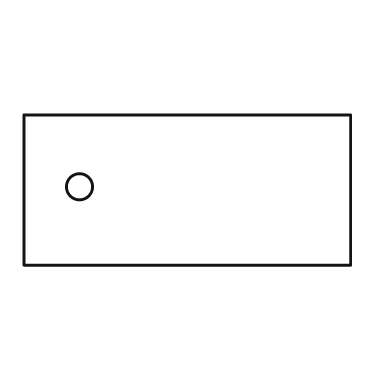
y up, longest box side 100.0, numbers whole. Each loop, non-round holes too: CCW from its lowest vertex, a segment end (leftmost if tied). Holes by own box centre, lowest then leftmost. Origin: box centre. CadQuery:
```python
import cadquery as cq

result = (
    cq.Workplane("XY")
    .moveTo(-50.0, -23.0)
    .lineTo(50.0, -23.0)
    .lineTo(50.0, 23.0)
    .lineTo(-50.0, 23.0)
    .close()
    .moveTo(-33.0, 1.0)
    .circle(4.0)
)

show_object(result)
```